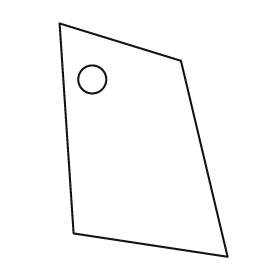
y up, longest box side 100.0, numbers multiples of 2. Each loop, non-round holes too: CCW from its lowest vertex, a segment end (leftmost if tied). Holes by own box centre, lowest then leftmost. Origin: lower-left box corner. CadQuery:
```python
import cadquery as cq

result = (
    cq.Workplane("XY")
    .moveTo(72.0, 0.0)
    .lineTo(52.0, 84.0)
    .lineTo(0.0, 100.0)
    .lineTo(6.0, 10.0)
    .close()
    .moveTo(14.0, 76.0)
    .circle(6.0)
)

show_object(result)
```